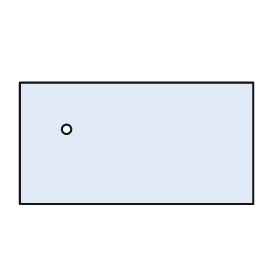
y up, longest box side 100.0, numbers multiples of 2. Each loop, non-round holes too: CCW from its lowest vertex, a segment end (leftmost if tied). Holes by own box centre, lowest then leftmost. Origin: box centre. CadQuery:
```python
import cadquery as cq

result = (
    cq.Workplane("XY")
    .moveTo(-50.0, -26.0)
    .lineTo(50.0, -26.0)
    .lineTo(50.0, 26.0)
    .lineTo(-50.0, 26.0)
    .close()
    .moveTo(-30.0, 6.0)
    .circle(2.0)
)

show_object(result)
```